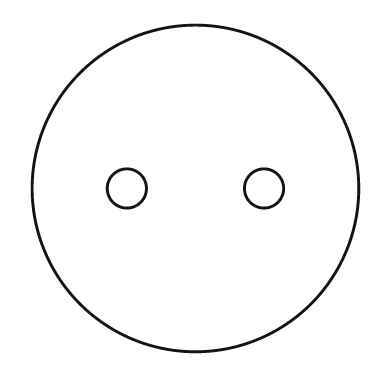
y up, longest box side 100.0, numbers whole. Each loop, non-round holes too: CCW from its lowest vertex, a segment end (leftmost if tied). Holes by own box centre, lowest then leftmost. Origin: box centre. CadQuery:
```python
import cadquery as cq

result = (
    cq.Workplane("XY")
    .moveTo(0.0, 0.0)
    .circle(50.0)
    .moveTo(-21.0, 0.0)
    .circle(6.0)
    .moveTo(21.0, 0.0)
    .circle(6.0)
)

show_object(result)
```